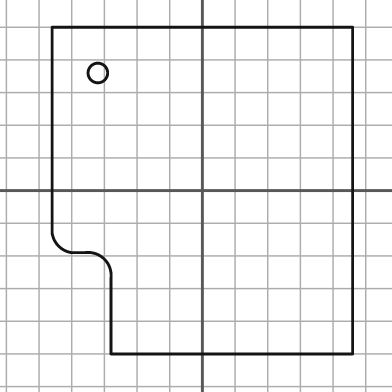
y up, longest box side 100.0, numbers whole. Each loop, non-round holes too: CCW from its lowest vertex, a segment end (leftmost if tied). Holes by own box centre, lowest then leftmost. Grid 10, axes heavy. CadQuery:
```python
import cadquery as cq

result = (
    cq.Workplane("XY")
    .moveTo(-28.0, -50.0)
    .lineTo(46.0, -50.0)
    .lineTo(46.0, 50.0)
    .lineTo(-46.0, 50.0)
    .lineTo(-46.0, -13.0)
    .threePointArc((-44.0, -17.0), (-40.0, -19.0))
    .lineTo(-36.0, -19.0)
    .threePointArc((-30.0, -21.0), (-28.0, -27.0))
    .close()
    .moveTo(-32.0, 36.0)
    .circle(3.0)
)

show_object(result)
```